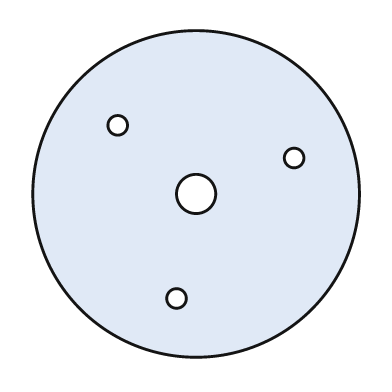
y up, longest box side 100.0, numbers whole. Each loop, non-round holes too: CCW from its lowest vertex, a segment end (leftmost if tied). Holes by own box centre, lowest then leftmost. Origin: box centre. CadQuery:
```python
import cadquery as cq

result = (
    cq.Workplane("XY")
    .moveTo(0.0, 0.0)
    .circle(50.0)
    .moveTo(-6.0, -32.0)
    .circle(3.0)
    .moveTo(0.0, 0.0)
    .circle(6.0)
    .moveTo(30.0, 11.0)
    .circle(3.0)
    .moveTo(-24.0, 21.0)
    .circle(3.0)
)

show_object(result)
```